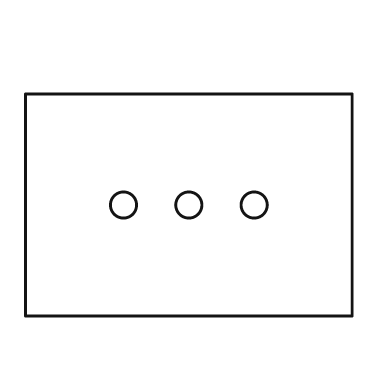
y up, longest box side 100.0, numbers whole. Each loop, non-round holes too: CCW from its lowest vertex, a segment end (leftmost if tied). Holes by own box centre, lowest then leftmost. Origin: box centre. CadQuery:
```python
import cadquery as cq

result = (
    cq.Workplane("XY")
    .moveTo(-50.0, -34.0)
    .lineTo(50.0, -34.0)
    .lineTo(50.0, 34.0)
    .lineTo(-50.0, 34.0)
    .close()
    .moveTo(-20.0, 0.0)
    .circle(4.0)
    .moveTo(0.0, 0.0)
    .circle(4.0)
    .moveTo(20.0, 0.0)
    .circle(4.0)
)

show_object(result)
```